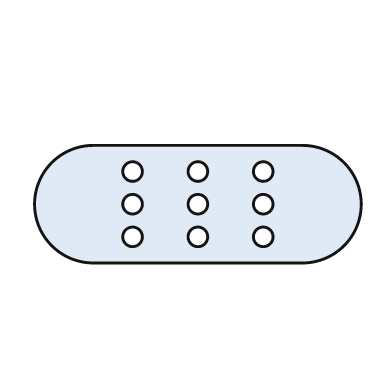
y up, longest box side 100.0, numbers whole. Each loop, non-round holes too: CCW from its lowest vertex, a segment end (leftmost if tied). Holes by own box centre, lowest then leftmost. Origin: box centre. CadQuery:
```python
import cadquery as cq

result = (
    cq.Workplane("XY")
    .moveTo(-32.0, -18.0)
    .lineTo(32.0, -18.0)
    .threePointArc((50.0, 0.0), (32.0, 18.0))
    .lineTo(-32.0, 18.0)
    .threePointArc((-50.0, 0.0), (-32.0, -18.0))
    .close()
    .moveTo(-20.0, -10.0)
    .circle(3.0)
    .moveTo(0.0, -10.0)
    .circle(3.0)
    .moveTo(20.0, -10.0)
    .circle(3.0)
    .moveTo(-20.0, 0.0)
    .circle(3.0)
    .moveTo(0.0, 0.0)
    .circle(3.0)
    .moveTo(20.0, 0.0)
    .circle(3.0)
    .moveTo(-20.0, 10.0)
    .circle(3.0)
    .moveTo(0.0, 10.0)
    .circle(3.0)
    .moveTo(20.0, 10.0)
    .circle(3.0)
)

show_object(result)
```